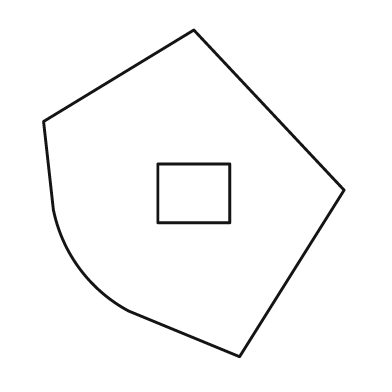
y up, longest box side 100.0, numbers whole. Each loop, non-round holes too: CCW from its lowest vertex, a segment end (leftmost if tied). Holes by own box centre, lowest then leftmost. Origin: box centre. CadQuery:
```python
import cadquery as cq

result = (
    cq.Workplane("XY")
    .moveTo(14.0, -50.0)
    .lineTo(46.0, 1.0)
    .lineTo(0.0, 50.0)
    .lineTo(-46.0, 22.0)
    .lineTo(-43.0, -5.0)
    .threePointArc((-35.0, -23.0), (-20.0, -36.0))
    .close()
    .moveTo(-11.0, -9.0)
    .lineTo(11.0, -9.0)
    .lineTo(11.0, 9.0)
    .lineTo(-11.0, 9.0)
    .close()
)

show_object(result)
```